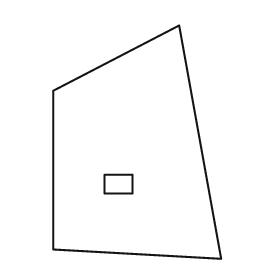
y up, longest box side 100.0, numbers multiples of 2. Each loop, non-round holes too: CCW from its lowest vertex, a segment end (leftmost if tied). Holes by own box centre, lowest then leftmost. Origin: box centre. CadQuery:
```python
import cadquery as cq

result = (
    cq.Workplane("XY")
    .moveTo(36.0, -50.0)
    .lineTo(18.0, 50.0)
    .lineTo(-36.0, 22.0)
    .lineTo(-36.0, -46.0)
    .close()
    .moveTo(-14.0, -22.0)
    .lineTo(-2.0, -22.0)
    .lineTo(-2.0, -14.0)
    .lineTo(-14.0, -14.0)
    .close()
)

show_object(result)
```